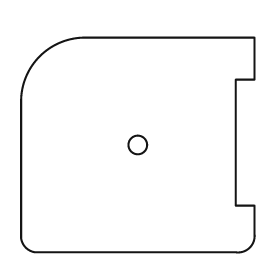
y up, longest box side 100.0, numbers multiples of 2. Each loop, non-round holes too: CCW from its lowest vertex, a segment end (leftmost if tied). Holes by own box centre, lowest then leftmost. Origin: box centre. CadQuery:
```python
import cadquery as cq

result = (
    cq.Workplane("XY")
    .moveTo(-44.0, -46.0)
    .lineTo(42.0, -46.0)
    .threePointArc((48.0, -44.0), (50.0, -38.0))
    .lineTo(50.0, -26.0)
    .lineTo(42.0, -26.0)
    .lineTo(42.0, 28.0)
    .lineTo(50.0, 28.0)
    .lineTo(50.0, 46.0)
    .lineTo(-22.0, 46.0)
    .threePointArc((-42.0, 38.0), (-50.0, 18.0))
    .lineTo(-50.0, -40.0)
    .threePointArc((-48.0, -44.0), (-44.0, -46.0))
    .close()
    .moveTo(0.0, 0.0)
    .circle(4.0)
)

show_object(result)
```